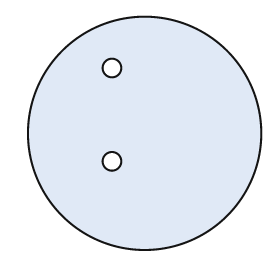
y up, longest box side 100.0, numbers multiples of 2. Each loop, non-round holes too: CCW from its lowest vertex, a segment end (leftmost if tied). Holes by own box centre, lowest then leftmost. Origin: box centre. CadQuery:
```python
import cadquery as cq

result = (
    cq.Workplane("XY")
    .moveTo(0.0, 0.0)
    .circle(50.0)
    .moveTo(-14.0, -12.0)
    .circle(4.0)
    .moveTo(-14.0, 28.0)
    .circle(4.0)
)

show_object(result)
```